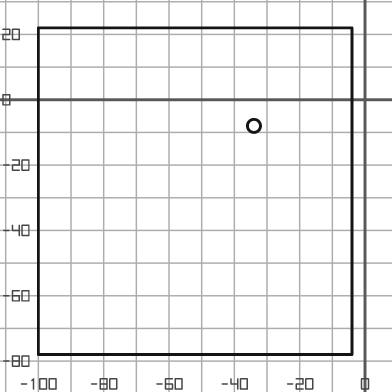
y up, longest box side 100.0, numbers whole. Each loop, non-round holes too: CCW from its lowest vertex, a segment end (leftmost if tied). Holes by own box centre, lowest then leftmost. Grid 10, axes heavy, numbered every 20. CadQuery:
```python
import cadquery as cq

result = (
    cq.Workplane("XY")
    .moveTo(-100.0, -78.0)
    .lineTo(-4.0, -78.0)
    .lineTo(-4.0, 22.0)
    .lineTo(-100.0, 22.0)
    .close()
    .moveTo(-34.0, -8.0)
    .circle(2.0)
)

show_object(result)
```